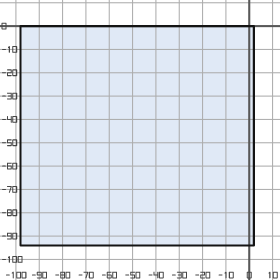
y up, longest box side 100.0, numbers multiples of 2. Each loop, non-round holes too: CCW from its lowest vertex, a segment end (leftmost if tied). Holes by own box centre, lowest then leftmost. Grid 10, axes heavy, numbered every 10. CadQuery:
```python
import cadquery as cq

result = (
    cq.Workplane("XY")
    .moveTo(-98.0, -94.0)
    .lineTo(2.0, -94.0)
    .lineTo(2.0, 0.0)
    .lineTo(-98.0, 0.0)
    .close()
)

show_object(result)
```